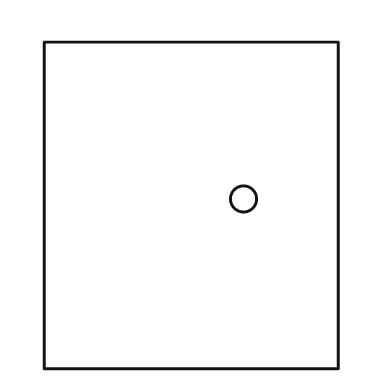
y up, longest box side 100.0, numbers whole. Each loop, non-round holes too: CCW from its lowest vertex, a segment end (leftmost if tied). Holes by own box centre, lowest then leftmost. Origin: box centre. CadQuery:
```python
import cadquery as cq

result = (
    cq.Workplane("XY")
    .moveTo(-45.0, -50.0)
    .lineTo(45.0, -50.0)
    .lineTo(45.0, 50.0)
    .lineTo(-45.0, 50.0)
    .close()
    .moveTo(16.0, 2.0)
    .circle(4.0)
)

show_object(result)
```